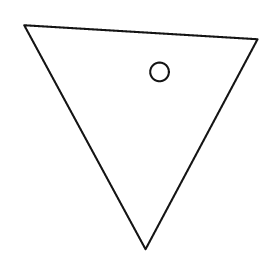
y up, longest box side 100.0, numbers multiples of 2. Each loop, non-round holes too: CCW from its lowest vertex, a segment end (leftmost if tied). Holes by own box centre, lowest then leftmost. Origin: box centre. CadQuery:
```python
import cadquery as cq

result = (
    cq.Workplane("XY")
    .moveTo(2.0, -48.0)
    .lineTo(50.0, 42.0)
    .lineTo(-50.0, 48.0)
    .close()
    .moveTo(8.0, 28.0)
    .circle(4.0)
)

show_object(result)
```